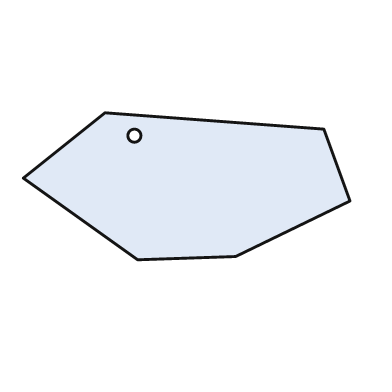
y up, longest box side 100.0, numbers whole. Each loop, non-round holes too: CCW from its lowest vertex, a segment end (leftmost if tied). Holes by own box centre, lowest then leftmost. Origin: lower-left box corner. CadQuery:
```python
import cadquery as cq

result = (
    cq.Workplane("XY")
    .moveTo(35.0, 0.0)
    .lineTo(65.0, 1.0)
    .lineTo(100.0, 18.0)
    .lineTo(92.0, 40.0)
    .lineTo(25.0, 45.0)
    .lineTo(0.0, 25.0)
    .close()
    .moveTo(34.0, 38.0)
    .circle(2.0)
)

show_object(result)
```